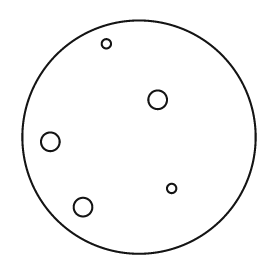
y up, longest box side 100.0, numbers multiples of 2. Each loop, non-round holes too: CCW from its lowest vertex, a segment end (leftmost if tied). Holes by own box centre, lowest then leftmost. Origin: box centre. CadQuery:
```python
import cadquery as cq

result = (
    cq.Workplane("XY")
    .moveTo(0.0, 0.0)
    .circle(50.0)
    .moveTo(-24.0, -30.0)
    .circle(4.0)
    .moveTo(14.0, -22.0)
    .circle(2.0)
    .moveTo(-38.0, -2.0)
    .circle(4.0)
    .moveTo(8.0, 16.0)
    .circle(4.0)
    .moveTo(-14.0, 40.0)
    .circle(2.0)
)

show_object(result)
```